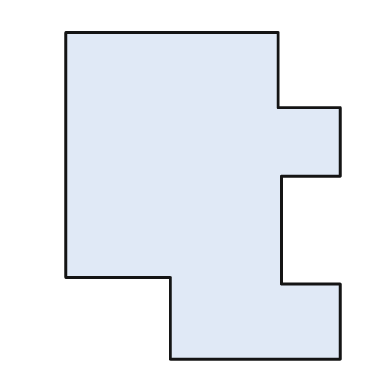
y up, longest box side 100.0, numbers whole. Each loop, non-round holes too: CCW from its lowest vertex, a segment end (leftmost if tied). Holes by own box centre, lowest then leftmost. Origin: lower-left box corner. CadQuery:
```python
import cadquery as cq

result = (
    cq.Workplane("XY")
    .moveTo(32.0, 0.0)
    .lineTo(84.0, 0.0)
    .lineTo(84.0, 23.0)
    .lineTo(66.0, 23.0)
    .lineTo(66.0, 56.0)
    .lineTo(84.0, 56.0)
    .lineTo(84.0, 77.0)
    .lineTo(65.0, 77.0)
    .lineTo(65.0, 100.0)
    .lineTo(0.0, 100.0)
    .lineTo(0.0, 25.0)
    .lineTo(32.0, 25.0)
    .close()
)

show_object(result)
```